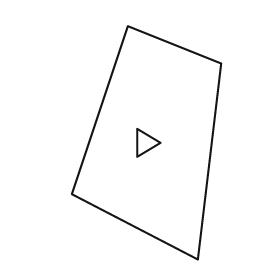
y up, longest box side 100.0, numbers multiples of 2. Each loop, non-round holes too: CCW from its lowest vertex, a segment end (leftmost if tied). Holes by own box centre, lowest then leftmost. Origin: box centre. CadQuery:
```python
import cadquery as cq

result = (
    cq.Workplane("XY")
    .moveTo(22.0, -50.0)
    .lineTo(32.0, 34.0)
    .lineTo(-8.0, 50.0)
    .lineTo(-32.0, -22.0)
    .close()
    .moveTo(-4.0, -6.0)
    .lineTo(6.0, 0.0)
    .lineTo(-4.0, 6.0)
    .close()
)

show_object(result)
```